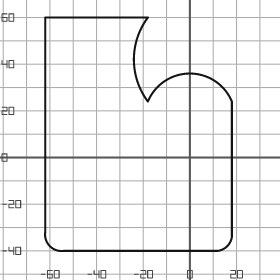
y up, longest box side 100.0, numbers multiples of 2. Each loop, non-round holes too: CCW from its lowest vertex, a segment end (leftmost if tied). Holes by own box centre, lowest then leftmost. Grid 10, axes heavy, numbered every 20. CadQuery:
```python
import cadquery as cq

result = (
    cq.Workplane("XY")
    .moveTo(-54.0, -40.0)
    .lineTo(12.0, -40.0)
    .threePointArc((16.0, -38.0), (18.0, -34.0))
    .lineTo(18.0, 24.0)
    .threePointArc((0.0, 36.0), (-18.0, 24.0))
    .threePointArc((-24.0, 42.0), (-18.0, 60.0))
    .lineTo(-62.0, 60.0)
    .lineTo(-62.0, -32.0)
    .threePointArc((-60.0, -38.0), (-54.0, -40.0))
    .close()
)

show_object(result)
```